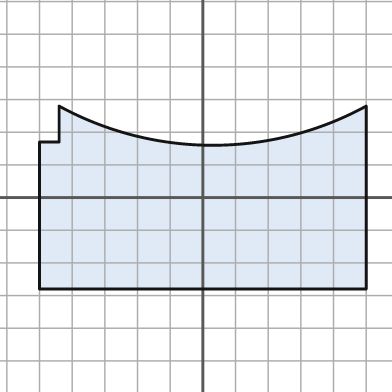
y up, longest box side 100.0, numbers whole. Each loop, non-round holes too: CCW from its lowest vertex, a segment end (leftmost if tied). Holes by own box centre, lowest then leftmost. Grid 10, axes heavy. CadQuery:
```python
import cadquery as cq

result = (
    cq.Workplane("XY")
    .moveTo(-50.0, -28.0)
    .lineTo(50.0, -28.0)
    .lineTo(50.0, 28.0)
    .threePointArc((3.0, 16.0), (-44.0, 28.0))
    .lineTo(-44.0, 17.0)
    .lineTo(-50.0, 17.0)
    .close()
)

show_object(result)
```